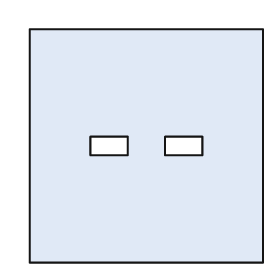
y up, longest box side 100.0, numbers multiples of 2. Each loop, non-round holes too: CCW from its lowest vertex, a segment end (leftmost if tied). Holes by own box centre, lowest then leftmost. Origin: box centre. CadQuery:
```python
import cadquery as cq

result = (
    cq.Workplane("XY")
    .moveTo(-50.0, -50.0)
    .lineTo(50.0, -50.0)
    .lineTo(50.0, 50.0)
    .lineTo(-50.0, 50.0)
    .close()
    .moveTo(-24.0, -4.0)
    .lineTo(-8.0, -4.0)
    .lineTo(-8.0, 4.0)
    .lineTo(-24.0, 4.0)
    .close()
    .moveTo(8.0, -4.0)
    .lineTo(24.0, -4.0)
    .lineTo(24.0, 4.0)
    .lineTo(8.0, 4.0)
    .close()
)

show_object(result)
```